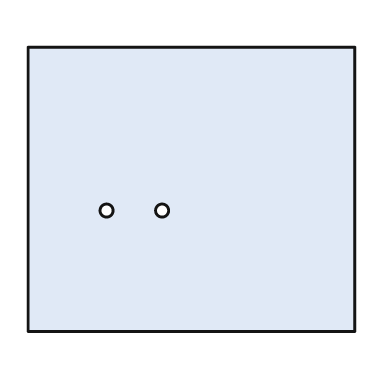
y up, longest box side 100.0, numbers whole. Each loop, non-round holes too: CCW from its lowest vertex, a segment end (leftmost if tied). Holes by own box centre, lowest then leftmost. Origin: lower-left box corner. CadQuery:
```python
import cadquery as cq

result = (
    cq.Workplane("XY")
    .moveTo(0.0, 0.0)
    .lineTo(100.0, 0.0)
    .lineTo(100.0, 87.0)
    .lineTo(0.0, 87.0)
    .close()
    .moveTo(24.0, 37.0)
    .circle(2.0)
    .moveTo(41.0, 37.0)
    .circle(2.0)
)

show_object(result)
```